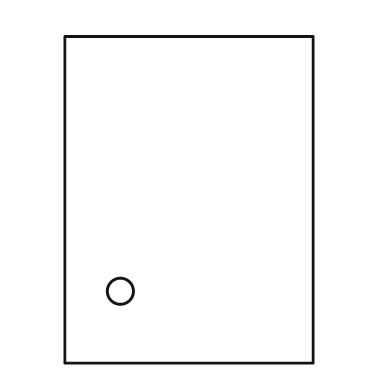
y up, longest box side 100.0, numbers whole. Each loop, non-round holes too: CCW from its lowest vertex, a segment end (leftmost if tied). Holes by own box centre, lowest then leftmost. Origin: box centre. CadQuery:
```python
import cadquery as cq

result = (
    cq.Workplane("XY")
    .moveTo(-38.0, -50.0)
    .lineTo(38.0, -50.0)
    .lineTo(38.0, 50.0)
    .lineTo(-38.0, 50.0)
    .close()
    .moveTo(-21.0, -28.0)
    .circle(4.0)
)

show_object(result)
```